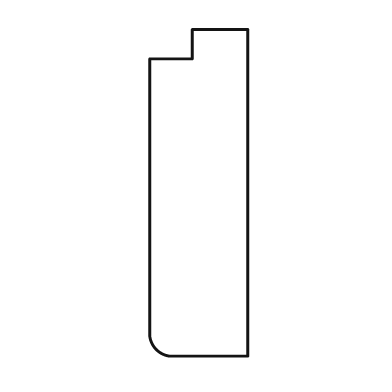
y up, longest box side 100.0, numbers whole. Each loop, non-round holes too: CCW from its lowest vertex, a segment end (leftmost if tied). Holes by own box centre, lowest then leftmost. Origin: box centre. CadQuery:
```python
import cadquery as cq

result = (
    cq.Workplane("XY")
    .moveTo(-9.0, -50.0)
    .lineTo(15.0, -50.0)
    .lineTo(15.0, 50.0)
    .lineTo(-2.0, 50.0)
    .lineTo(-2.0, 41.0)
    .lineTo(-15.0, 41.0)
    .lineTo(-15.0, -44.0)
    .threePointArc((-13.0, -48.0), (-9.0, -50.0))
    .close()
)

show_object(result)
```